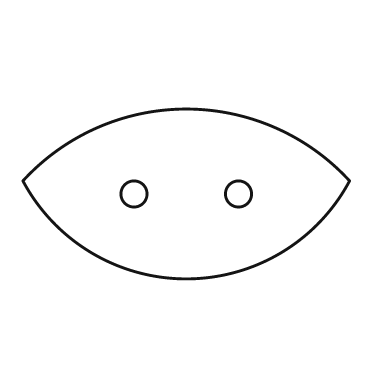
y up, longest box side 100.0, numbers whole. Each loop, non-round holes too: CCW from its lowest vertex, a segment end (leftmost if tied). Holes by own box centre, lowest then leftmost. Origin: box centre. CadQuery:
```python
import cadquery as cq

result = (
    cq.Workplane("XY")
    .moveTo(-50.0, 4.0)
    .threePointArc((0.0, -26.0), (50.0, 4.0))
    .threePointArc((0.0, 26.0), (-50.0, 4.0))
    .close()
    .moveTo(-16.0, 0.0)
    .circle(4.0)
    .moveTo(16.0, 0.0)
    .circle(4.0)
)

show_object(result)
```